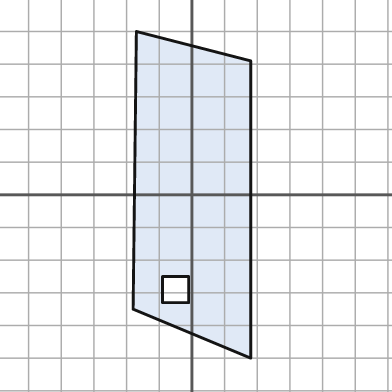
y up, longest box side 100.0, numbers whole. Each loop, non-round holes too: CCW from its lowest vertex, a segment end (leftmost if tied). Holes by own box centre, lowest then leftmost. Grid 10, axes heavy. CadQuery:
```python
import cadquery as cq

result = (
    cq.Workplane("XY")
    .moveTo(18.0, -50.0)
    .lineTo(18.0, 41.0)
    .lineTo(-17.0, 50.0)
    .lineTo(-18.0, -35.0)
    .close()
    .moveTo(-9.0, -33.0)
    .lineTo(-1.0, -33.0)
    .lineTo(-1.0, -25.0)
    .lineTo(-9.0, -25.0)
    .close()
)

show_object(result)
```